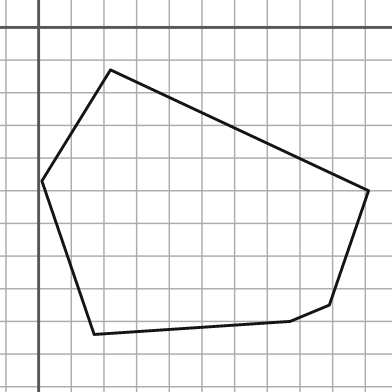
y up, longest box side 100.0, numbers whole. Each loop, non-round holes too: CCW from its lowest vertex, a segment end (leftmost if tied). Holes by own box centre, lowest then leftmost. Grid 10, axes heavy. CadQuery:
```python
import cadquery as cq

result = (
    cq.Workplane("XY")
    .moveTo(17.0, -94.0)
    .lineTo(77.0, -90.0)
    .lineTo(89.0, -85.0)
    .lineTo(101.0, -50.0)
    .lineTo(22.0, -13.0)
    .lineTo(1.0, -47.0)
    .close()
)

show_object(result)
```